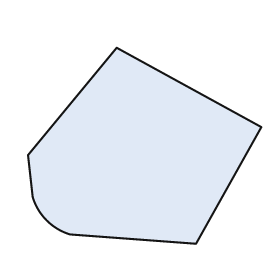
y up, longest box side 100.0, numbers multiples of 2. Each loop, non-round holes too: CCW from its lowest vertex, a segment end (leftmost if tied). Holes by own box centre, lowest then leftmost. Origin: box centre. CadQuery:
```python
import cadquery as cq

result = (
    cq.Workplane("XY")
    .moveTo(22.0, -42.0)
    .lineTo(50.0, 8.0)
    .lineTo(-12.0, 42.0)
    .lineTo(-50.0, -4.0)
    .lineTo(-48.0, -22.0)
    .threePointArc((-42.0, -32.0), (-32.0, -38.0))
    .close()
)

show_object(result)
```